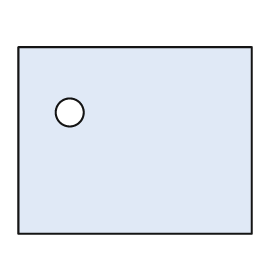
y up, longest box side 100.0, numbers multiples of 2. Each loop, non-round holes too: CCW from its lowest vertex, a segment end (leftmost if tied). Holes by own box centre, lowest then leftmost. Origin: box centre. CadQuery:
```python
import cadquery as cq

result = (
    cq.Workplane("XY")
    .moveTo(-50.0, -40.0)
    .lineTo(50.0, -40.0)
    .lineTo(50.0, 40.0)
    .lineTo(-50.0, 40.0)
    .close()
    .moveTo(-28.0, 12.0)
    .circle(6.0)
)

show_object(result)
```